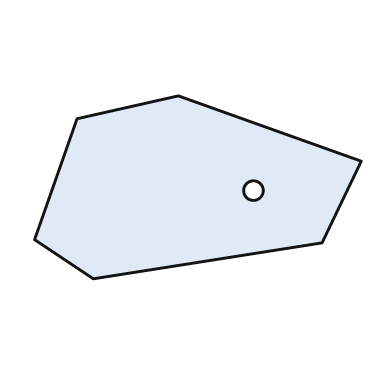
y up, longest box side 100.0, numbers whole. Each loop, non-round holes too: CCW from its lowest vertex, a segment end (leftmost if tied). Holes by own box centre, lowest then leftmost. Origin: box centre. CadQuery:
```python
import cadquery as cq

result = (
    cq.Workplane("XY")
    .moveTo(-32.0, -28.0)
    .lineTo(38.0, -17.0)
    .lineTo(50.0, 8.0)
    .lineTo(-6.0, 28.0)
    .lineTo(-37.0, 21.0)
    .lineTo(-50.0, -16.0)
    .close()
    .moveTo(17.0, -1.0)
    .circle(3.0)
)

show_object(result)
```